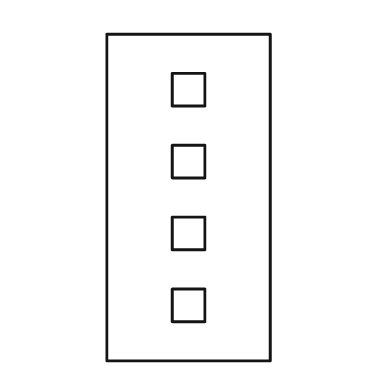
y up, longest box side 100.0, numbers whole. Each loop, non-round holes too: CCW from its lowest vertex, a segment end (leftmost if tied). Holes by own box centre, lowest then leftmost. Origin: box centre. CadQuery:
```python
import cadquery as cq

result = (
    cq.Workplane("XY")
    .moveTo(-25.0, -50.0)
    .lineTo(25.0, -50.0)
    .lineTo(25.0, 50.0)
    .lineTo(-25.0, 50.0)
    .close()
    .moveTo(-5.0, -38.0)
    .lineTo(5.0, -38.0)
    .lineTo(5.0, -28.0)
    .lineTo(-5.0, -28.0)
    .close()
    .moveTo(-5.0, -16.0)
    .lineTo(5.0, -16.0)
    .lineTo(5.0, -6.0)
    .lineTo(-5.0, -6.0)
    .close()
    .moveTo(-5.0, 6.0)
    .lineTo(5.0, 6.0)
    .lineTo(5.0, 16.0)
    .lineTo(-5.0, 16.0)
    .close()
    .moveTo(-5.0, 28.0)
    .lineTo(5.0, 28.0)
    .lineTo(5.0, 38.0)
    .lineTo(-5.0, 38.0)
    .close()
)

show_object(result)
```